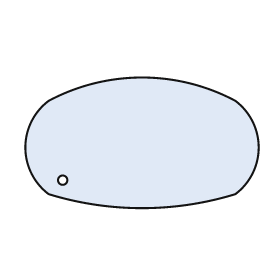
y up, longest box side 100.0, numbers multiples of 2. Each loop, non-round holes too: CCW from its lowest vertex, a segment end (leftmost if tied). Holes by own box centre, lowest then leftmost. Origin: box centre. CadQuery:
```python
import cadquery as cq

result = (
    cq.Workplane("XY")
    .moveTo(-40.0, -22.0)
    .threePointArc((0.0, -28.0), (40.0, -22.0))
    .threePointArc((50.0, -2.0), (40.0, 18.0))
    .threePointArc((0.0, 28.0), (-40.0, 18.0))
    .threePointArc((-50.0, -2.0), (-40.0, -22.0))
    .close()
    .moveTo(-34.0, -16.0)
    .circle(2.0)
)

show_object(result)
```